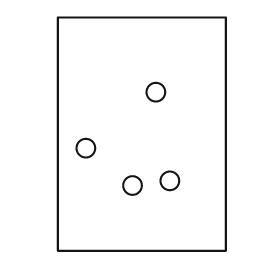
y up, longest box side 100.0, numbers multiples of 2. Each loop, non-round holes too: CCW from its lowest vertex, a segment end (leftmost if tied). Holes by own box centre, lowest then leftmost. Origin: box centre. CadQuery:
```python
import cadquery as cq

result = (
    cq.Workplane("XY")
    .moveTo(-36.0, -50.0)
    .lineTo(36.0, -50.0)
    .lineTo(36.0, 50.0)
    .lineTo(-36.0, 50.0)
    .close()
    .moveTo(-4.0, -22.0)
    .circle(4.0)
    .moveTo(12.0, -20.0)
    .circle(4.0)
    .moveTo(-24.0, -6.0)
    .circle(4.0)
    .moveTo(6.0, 18.0)
    .circle(4.0)
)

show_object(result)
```